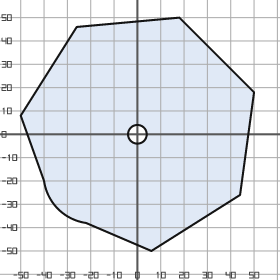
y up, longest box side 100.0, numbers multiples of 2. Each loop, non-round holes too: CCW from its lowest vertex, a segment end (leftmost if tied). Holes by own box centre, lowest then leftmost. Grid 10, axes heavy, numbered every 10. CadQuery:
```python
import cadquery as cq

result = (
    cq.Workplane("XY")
    .moveTo(6.0, -50.0)
    .lineTo(44.0, -26.0)
    .lineTo(50.0, 18.0)
    .lineTo(18.0, 50.0)
    .lineTo(-26.0, 46.0)
    .lineTo(-50.0, 8.0)
    .lineTo(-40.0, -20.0)
    .threePointArc((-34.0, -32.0), (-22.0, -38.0))
    .close()
    .moveTo(0.0, 0.0)
    .circle(4.0)
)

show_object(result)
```